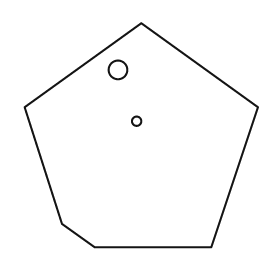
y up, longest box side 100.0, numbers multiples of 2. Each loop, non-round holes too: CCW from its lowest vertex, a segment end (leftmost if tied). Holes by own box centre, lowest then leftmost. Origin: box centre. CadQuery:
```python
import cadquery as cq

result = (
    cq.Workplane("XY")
    .moveTo(-20.0, -48.0)
    .lineTo(30.0, -48.0)
    .lineTo(50.0, 12.0)
    .lineTo(0.0, 48.0)
    .lineTo(-50.0, 12.0)
    .lineTo(-34.0, -38.0)
    .close()
    .moveTo(-2.0, 6.0)
    .circle(2.0)
    .moveTo(-10.0, 28.0)
    .circle(4.0)
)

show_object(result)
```